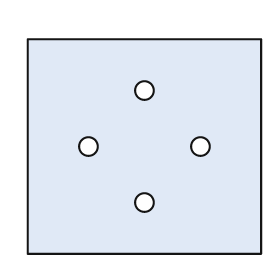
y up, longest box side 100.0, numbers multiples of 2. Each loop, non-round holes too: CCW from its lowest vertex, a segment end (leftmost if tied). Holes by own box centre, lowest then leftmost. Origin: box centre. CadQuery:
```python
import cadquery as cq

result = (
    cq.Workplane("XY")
    .moveTo(-50.0, -46.0)
    .lineTo(50.0, -46.0)
    .lineTo(50.0, 46.0)
    .lineTo(-50.0, 46.0)
    .close()
    .moveTo(0.0, -24.0)
    .circle(4.0)
    .moveTo(-24.0, 0.0)
    .circle(4.0)
    .moveTo(24.0, 0.0)
    .circle(4.0)
    .moveTo(0.0, 24.0)
    .circle(4.0)
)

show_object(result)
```